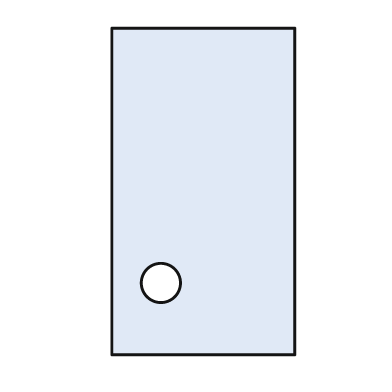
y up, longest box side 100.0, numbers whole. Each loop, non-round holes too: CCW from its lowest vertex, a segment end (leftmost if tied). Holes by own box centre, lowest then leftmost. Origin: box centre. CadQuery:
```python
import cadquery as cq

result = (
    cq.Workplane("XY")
    .moveTo(-28.0, -50.0)
    .lineTo(28.0, -50.0)
    .lineTo(28.0, 50.0)
    .lineTo(-28.0, 50.0)
    .close()
    .moveTo(-13.0, -28.0)
    .circle(6.0)
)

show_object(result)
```